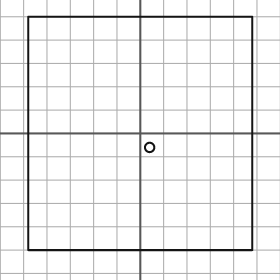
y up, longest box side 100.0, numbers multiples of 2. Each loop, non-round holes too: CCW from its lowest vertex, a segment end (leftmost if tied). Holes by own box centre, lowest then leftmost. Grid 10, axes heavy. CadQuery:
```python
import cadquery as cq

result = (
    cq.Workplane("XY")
    .moveTo(-48.0, -50.0)
    .lineTo(48.0, -50.0)
    .lineTo(48.0, 50.0)
    .lineTo(-48.0, 50.0)
    .close()
    .moveTo(4.0, -6.0)
    .circle(2.0)
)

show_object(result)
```